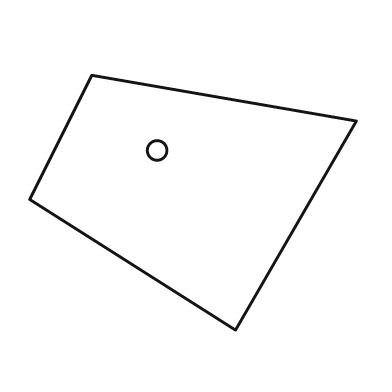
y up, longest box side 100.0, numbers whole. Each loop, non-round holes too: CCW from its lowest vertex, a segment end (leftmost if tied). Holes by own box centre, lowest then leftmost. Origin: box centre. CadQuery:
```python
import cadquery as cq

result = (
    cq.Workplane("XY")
    .moveTo(13.0, -39.0)
    .lineTo(50.0, 25.0)
    .lineTo(-31.0, 39.0)
    .lineTo(-50.0, 1.0)
    .close()
    .moveTo(-11.0, 16.0)
    .circle(3.0)
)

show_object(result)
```